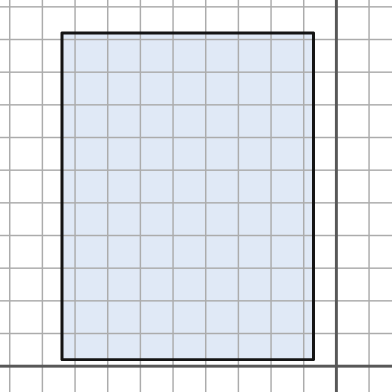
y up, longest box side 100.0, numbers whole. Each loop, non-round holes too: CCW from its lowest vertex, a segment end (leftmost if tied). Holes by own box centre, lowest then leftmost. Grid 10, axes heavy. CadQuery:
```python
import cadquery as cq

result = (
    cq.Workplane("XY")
    .moveTo(-84.0, 2.0)
    .lineTo(-7.0, 2.0)
    .lineTo(-7.0, 102.0)
    .lineTo(-84.0, 102.0)
    .close()
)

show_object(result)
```